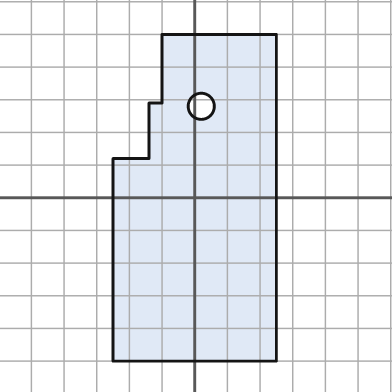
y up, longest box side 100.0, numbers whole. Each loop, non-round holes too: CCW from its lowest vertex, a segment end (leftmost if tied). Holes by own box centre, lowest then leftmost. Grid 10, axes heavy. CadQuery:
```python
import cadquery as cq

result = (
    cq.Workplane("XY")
    .moveTo(-25.0, -50.0)
    .lineTo(25.0, -50.0)
    .lineTo(25.0, 50.0)
    .lineTo(-10.0, 50.0)
    .lineTo(-10.0, 29.0)
    .lineTo(-14.0, 29.0)
    .lineTo(-14.0, 12.0)
    .lineTo(-25.0, 12.0)
    .close()
    .moveTo(2.0, 28.0)
    .circle(4.0)
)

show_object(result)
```